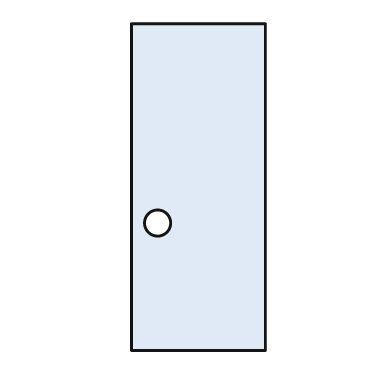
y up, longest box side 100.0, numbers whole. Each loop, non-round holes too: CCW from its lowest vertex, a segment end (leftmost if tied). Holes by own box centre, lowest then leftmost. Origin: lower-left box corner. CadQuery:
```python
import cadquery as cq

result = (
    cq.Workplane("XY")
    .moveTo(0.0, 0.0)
    .lineTo(41.0, 0.0)
    .lineTo(41.0, 100.0)
    .lineTo(0.0, 100.0)
    .close()
    .moveTo(8.0, 39.0)
    .circle(4.0)
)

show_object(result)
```